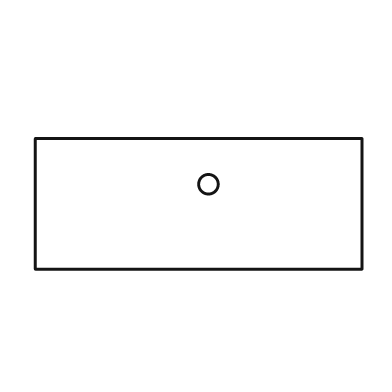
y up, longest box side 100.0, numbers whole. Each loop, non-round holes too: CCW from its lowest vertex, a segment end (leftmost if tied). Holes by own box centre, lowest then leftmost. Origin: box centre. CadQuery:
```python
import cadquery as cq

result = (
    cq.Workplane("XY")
    .moveTo(-50.0, -20.0)
    .lineTo(50.0, -20.0)
    .lineTo(50.0, 20.0)
    .lineTo(-50.0, 20.0)
    .close()
    .moveTo(3.0, 6.0)
    .circle(3.0)
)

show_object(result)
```